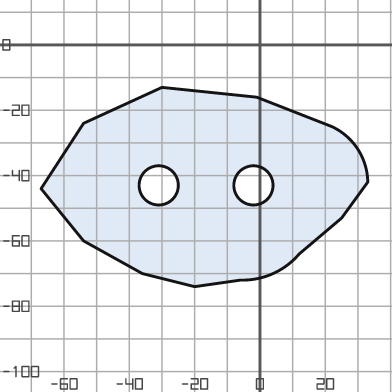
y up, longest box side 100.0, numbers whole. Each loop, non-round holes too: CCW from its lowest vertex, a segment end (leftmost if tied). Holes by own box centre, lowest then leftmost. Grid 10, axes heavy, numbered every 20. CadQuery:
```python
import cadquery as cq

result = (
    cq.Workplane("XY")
    .moveTo(-20.0, -74.0)
    .lineTo(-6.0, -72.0)
    .threePointArc((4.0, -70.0), (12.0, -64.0))
    .lineTo(25.0, -53.0)
    .lineTo(33.0, -42.0)
    .threePointArc((30.0, -32.0), (22.0, -25.0))
    .lineTo(-1.0, -16.0)
    .lineTo(-30.0, -13.0)
    .lineTo(-54.0, -24.0)
    .lineTo(-67.0, -44.0)
    .lineTo(-54.0, -60.0)
    .lineTo(-36.0, -70.0)
    .close()
    .moveTo(-31.0, -43.0)
    .circle(6.0)
    .moveTo(-2.0, -43.0)
    .circle(6.0)
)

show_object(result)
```